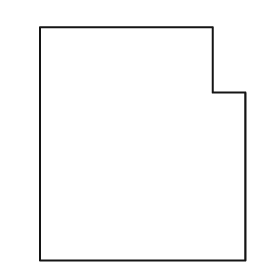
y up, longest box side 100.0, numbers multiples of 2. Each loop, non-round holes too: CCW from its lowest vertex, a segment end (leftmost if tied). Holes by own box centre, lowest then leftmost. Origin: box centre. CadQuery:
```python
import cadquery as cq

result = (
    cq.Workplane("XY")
    .moveTo(-44.0, -50.0)
    .lineTo(44.0, -50.0)
    .lineTo(44.0, 22.0)
    .lineTo(30.0, 22.0)
    .lineTo(30.0, 50.0)
    .lineTo(-44.0, 50.0)
    .close()
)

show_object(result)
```